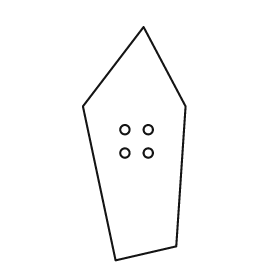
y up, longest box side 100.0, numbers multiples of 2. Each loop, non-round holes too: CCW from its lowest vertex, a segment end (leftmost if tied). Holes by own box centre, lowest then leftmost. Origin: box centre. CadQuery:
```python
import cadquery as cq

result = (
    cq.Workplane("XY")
    .moveTo(-8.0, -50.0)
    .lineTo(18.0, -44.0)
    .lineTo(22.0, 16.0)
    .lineTo(4.0, 50.0)
    .lineTo(-22.0, 16.0)
    .close()
    .moveTo(-4.0, -4.0)
    .circle(2.0)
    .moveTo(6.0, -4.0)
    .circle(2.0)
    .moveTo(-4.0, 6.0)
    .circle(2.0)
    .moveTo(6.0, 6.0)
    .circle(2.0)
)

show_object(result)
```